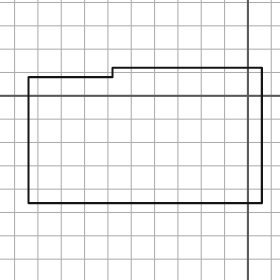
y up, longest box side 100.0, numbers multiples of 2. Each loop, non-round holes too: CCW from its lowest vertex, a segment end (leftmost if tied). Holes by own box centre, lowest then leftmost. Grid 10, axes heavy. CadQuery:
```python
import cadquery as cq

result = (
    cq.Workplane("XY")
    .moveTo(-94.0, -46.0)
    .lineTo(6.0, -46.0)
    .lineTo(6.0, 12.0)
    .lineTo(-58.0, 12.0)
    .lineTo(-58.0, 8.0)
    .lineTo(-94.0, 8.0)
    .close()
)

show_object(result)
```